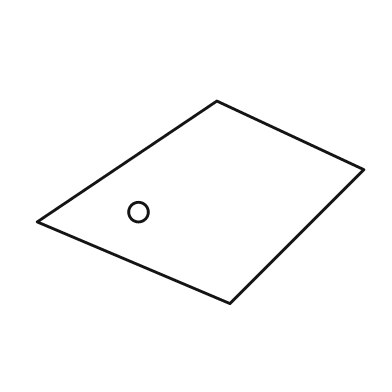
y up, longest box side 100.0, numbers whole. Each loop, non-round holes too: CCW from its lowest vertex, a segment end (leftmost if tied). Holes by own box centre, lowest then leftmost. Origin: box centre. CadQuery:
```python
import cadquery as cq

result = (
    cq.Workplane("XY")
    .moveTo(9.0, -31.0)
    .lineTo(50.0, 10.0)
    .lineTo(5.0, 31.0)
    .lineTo(-50.0, -6.0)
    .close()
    .moveTo(-19.0, -3.0)
    .circle(3.0)
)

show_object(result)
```